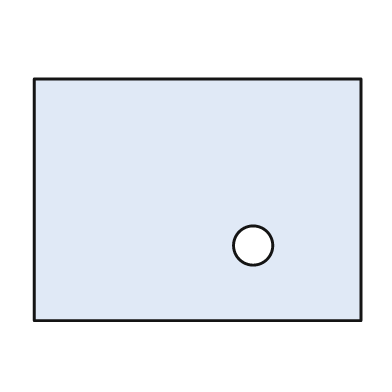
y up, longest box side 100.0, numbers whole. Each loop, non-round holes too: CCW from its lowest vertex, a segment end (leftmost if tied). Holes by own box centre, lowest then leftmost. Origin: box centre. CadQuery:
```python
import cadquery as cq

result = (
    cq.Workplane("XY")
    .moveTo(-50.0, -37.0)
    .lineTo(50.0, -37.0)
    .lineTo(50.0, 37.0)
    .lineTo(-50.0, 37.0)
    .close()
    .moveTo(17.0, -14.0)
    .circle(6.0)
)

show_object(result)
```